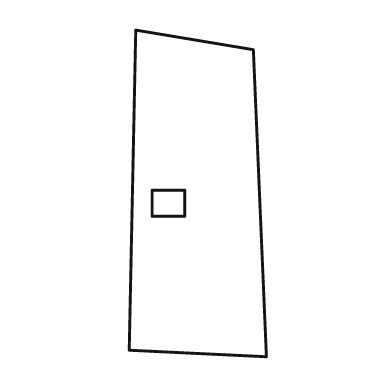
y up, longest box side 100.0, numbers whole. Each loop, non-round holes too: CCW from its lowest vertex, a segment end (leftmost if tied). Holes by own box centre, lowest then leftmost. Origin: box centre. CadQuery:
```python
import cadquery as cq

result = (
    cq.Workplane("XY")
    .moveTo(21.0, -50.0)
    .lineTo(17.0, 44.0)
    .lineTo(-19.0, 50.0)
    .lineTo(-21.0, -48.0)
    .close()
    .moveTo(-14.0, -7.0)
    .lineTo(-4.0, -7.0)
    .lineTo(-4.0, 1.0)
    .lineTo(-14.0, 1.0)
    .close()
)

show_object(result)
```